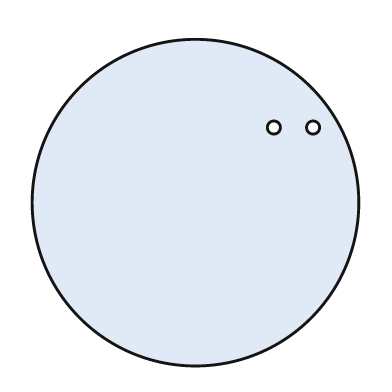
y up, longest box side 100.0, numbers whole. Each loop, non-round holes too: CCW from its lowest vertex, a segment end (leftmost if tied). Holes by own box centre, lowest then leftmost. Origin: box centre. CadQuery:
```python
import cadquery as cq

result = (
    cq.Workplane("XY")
    .moveTo(0.0, 0.0)
    .circle(50.0)
    .moveTo(24.0, 23.0)
    .circle(2.0)
    .moveTo(36.0, 23.0)
    .circle(2.0)
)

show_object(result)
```